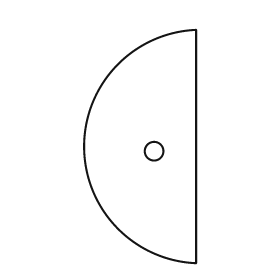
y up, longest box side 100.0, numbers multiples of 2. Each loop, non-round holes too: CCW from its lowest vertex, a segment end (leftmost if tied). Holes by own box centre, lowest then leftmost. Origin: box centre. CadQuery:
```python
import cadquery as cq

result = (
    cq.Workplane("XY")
    .moveTo(24.0, -50.0)
    .lineTo(24.0, 50.0)
    .threePointArc((-24.0, 0.0), (24.0, -50.0))
    .close()
    .moveTo(6.0, -2.0)
    .circle(4.0)
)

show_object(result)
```